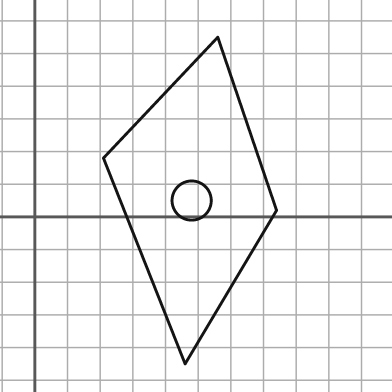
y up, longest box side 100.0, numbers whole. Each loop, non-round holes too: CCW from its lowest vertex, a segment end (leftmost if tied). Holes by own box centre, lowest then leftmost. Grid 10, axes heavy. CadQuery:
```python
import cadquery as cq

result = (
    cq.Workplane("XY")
    .moveTo(46.0, -45.0)
    .lineTo(74.0, 2.0)
    .lineTo(56.0, 55.0)
    .lineTo(21.0, 18.0)
    .close()
    .moveTo(48.0, 5.0)
    .circle(6.0)
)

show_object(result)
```